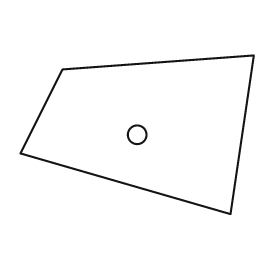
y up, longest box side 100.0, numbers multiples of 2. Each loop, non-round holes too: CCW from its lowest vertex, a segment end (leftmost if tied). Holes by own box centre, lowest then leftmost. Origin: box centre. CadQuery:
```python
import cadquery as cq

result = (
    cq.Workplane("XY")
    .moveTo(40.0, -34.0)
    .lineTo(50.0, 34.0)
    .lineTo(-32.0, 28.0)
    .lineTo(-50.0, -8.0)
    .close()
    .moveTo(0.0, 0.0)
    .circle(4.0)
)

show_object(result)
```